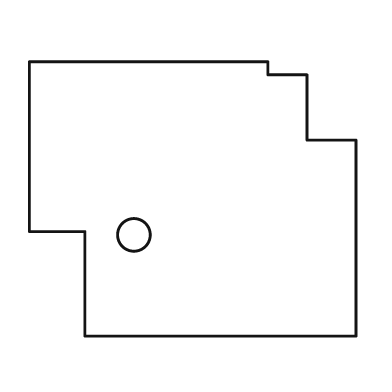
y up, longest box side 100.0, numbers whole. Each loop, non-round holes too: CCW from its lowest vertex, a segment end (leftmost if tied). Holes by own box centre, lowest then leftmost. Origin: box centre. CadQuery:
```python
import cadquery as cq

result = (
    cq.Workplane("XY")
    .moveTo(-33.0, -42.0)
    .lineTo(50.0, -42.0)
    .lineTo(50.0, 18.0)
    .lineTo(35.0, 18.0)
    .lineTo(35.0, 38.0)
    .lineTo(23.0, 38.0)
    .lineTo(23.0, 42.0)
    .lineTo(-50.0, 42.0)
    .lineTo(-50.0, -10.0)
    .lineTo(-33.0, -10.0)
    .close()
    .moveTo(-18.0, -11.0)
    .circle(5.0)
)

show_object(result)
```